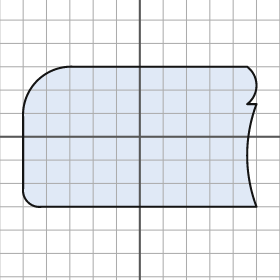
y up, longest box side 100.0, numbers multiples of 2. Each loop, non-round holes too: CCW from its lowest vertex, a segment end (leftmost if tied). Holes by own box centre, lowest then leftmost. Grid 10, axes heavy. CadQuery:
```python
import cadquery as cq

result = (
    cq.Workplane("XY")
    .moveTo(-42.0, -30.0)
    .lineTo(50.0, -30.0)
    .threePointArc((46.0, -8.0), (50.0, 14.0))
    .lineTo(46.0, 14.0)
    .threePointArc((50.0, 22.0), (46.0, 30.0))
    .lineTo(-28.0, 30.0)
    .threePointArc((-44.0, 24.0), (-50.0, 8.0))
    .lineTo(-50.0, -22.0)
    .threePointArc((-48.0, -28.0), (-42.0, -30.0))
    .close()
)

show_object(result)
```